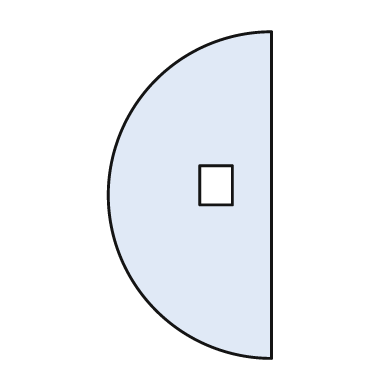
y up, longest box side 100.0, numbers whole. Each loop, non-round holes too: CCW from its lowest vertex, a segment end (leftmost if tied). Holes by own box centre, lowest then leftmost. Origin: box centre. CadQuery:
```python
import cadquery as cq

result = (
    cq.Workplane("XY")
    .moveTo(25.0, -50.0)
    .lineTo(25.0, 50.0)
    .threePointArc((-25.0, 0.0), (25.0, -50.0))
    .close()
    .moveTo(3.0, -3.0)
    .lineTo(13.0, -3.0)
    .lineTo(13.0, 9.0)
    .lineTo(3.0, 9.0)
    .close()
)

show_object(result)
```